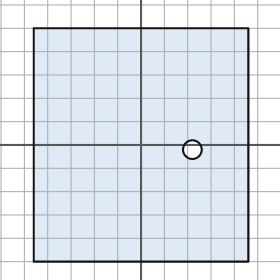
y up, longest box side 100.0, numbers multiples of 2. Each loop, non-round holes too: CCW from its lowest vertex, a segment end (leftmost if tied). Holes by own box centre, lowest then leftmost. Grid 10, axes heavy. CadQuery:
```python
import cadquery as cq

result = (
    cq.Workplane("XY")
    .moveTo(-46.0, -50.0)
    .lineTo(46.0, -50.0)
    .lineTo(46.0, 50.0)
    .lineTo(-46.0, 50.0)
    .close()
    .moveTo(22.0, -2.0)
    .circle(4.0)
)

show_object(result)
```